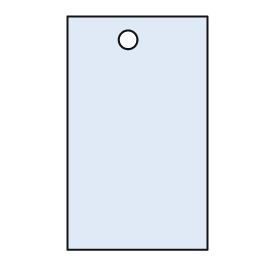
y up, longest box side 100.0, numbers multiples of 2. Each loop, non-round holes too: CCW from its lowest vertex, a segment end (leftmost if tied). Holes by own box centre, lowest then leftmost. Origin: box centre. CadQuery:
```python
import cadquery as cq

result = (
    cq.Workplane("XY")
    .moveTo(-30.0, -50.0)
    .lineTo(30.0, -50.0)
    .lineTo(30.0, 50.0)
    .lineTo(-30.0, 50.0)
    .close()
    .moveTo(-4.0, 40.0)
    .circle(4.0)
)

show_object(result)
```